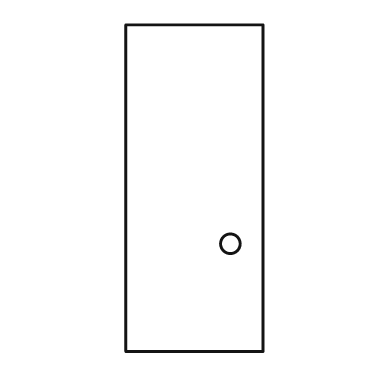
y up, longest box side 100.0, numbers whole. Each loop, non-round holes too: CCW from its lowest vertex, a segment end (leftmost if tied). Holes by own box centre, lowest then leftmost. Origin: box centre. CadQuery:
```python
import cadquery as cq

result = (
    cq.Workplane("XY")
    .moveTo(-21.0, -50.0)
    .lineTo(21.0, -50.0)
    .lineTo(21.0, 50.0)
    .lineTo(-21.0, 50.0)
    .close()
    .moveTo(11.0, -17.0)
    .circle(3.0)
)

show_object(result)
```